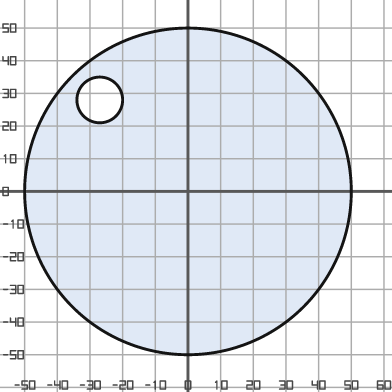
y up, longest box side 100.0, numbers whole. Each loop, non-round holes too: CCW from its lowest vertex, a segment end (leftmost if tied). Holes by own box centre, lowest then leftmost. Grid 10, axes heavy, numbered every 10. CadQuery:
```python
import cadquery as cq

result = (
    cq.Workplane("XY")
    .moveTo(0.0, 0.0)
    .circle(50.0)
    .moveTo(-27.0, 28.0)
    .circle(7.0)
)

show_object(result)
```